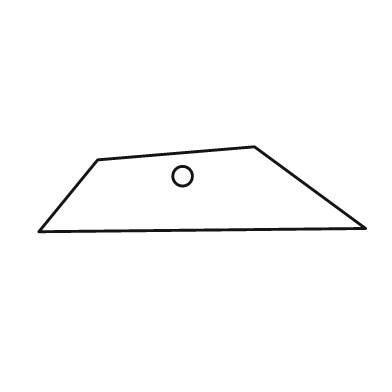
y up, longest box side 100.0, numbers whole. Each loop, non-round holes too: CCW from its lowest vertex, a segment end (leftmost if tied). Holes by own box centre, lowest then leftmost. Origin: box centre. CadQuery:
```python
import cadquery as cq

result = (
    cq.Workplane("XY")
    .moveTo(-50.0, -13.0)
    .lineTo(50.0, -12.0)
    .lineTo(16.0, 13.0)
    .lineTo(-32.0, 9.0)
    .close()
    .moveTo(-6.0, 4.0)
    .circle(3.0)
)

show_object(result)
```